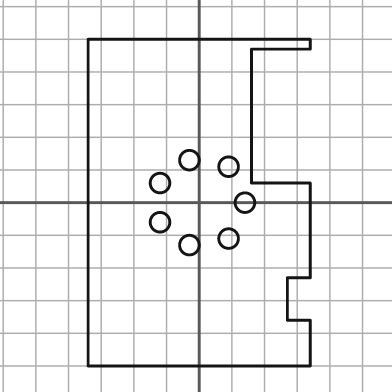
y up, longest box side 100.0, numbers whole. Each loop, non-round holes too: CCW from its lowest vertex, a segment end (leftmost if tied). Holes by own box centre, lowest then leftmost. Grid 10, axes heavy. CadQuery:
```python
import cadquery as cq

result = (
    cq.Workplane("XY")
    .moveTo(-34.0, -50.0)
    .lineTo(34.0, -50.0)
    .lineTo(34.0, -36.0)
    .lineTo(27.0, -36.0)
    .lineTo(27.0, -23.0)
    .lineTo(34.0, -23.0)
    .lineTo(34.0, 6.0)
    .lineTo(16.0, 6.0)
    .lineTo(16.0, 47.0)
    .lineTo(34.0, 47.0)
    .lineTo(34.0, 50.0)
    .lineTo(-34.0, 50.0)
    .close()
    .moveTo(-3.0, -13.0)
    .circle(3.0)
    .moveTo(9.0, -11.0)
    .circle(3.0)
    .moveTo(-12.0, -6.0)
    .circle(3.0)
    .moveTo(14.0, 0.0)
    .circle(3.0)
    .moveTo(-12.0, 6.0)
    .circle(3.0)
    .moveTo(9.0, 11.0)
    .circle(3.0)
    .moveTo(-3.0, 13.0)
    .circle(3.0)
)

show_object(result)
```